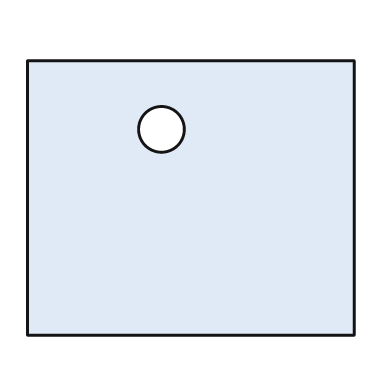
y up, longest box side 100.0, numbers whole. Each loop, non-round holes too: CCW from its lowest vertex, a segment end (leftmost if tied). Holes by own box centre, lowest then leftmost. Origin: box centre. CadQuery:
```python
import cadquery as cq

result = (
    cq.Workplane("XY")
    .moveTo(-50.0, -42.0)
    .lineTo(50.0, -42.0)
    .lineTo(50.0, 42.0)
    .lineTo(-50.0, 42.0)
    .close()
    .moveTo(-9.0, 21.0)
    .circle(7.0)
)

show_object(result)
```